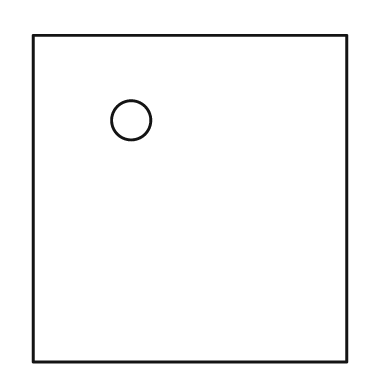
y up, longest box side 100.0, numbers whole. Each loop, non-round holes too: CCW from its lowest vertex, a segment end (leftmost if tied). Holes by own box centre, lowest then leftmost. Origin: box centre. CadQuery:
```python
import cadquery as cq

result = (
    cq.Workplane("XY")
    .moveTo(-48.0, -50.0)
    .lineTo(48.0, -50.0)
    .lineTo(48.0, 50.0)
    .lineTo(-48.0, 50.0)
    .close()
    .moveTo(-18.0, 24.0)
    .circle(6.0)
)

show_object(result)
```